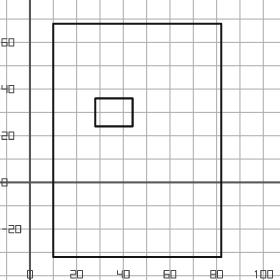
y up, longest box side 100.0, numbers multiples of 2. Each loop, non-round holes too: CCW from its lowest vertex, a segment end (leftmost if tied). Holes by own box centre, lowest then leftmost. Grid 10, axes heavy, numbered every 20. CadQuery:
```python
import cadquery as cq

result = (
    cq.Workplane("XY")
    .moveTo(10.0, -32.0)
    .lineTo(82.0, -32.0)
    .lineTo(82.0, 68.0)
    .lineTo(10.0, 68.0)
    .close()
    .moveTo(28.0, 24.0)
    .lineTo(44.0, 24.0)
    .lineTo(44.0, 36.0)
    .lineTo(28.0, 36.0)
    .close()
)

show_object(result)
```